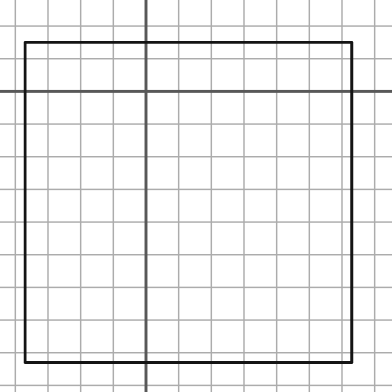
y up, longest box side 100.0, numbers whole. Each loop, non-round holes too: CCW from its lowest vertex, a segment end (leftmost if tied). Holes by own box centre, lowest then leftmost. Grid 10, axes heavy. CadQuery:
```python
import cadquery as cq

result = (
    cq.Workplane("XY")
    .moveTo(-37.0, -83.0)
    .lineTo(63.0, -83.0)
    .lineTo(63.0, 15.0)
    .lineTo(-37.0, 15.0)
    .close()
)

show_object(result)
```